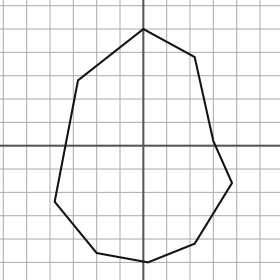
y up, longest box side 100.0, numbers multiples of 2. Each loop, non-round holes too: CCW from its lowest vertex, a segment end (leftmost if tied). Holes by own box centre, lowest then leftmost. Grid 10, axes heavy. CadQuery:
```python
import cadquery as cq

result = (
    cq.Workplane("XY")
    .moveTo(2.0, -50.0)
    .lineTo(22.0, -42.0)
    .lineTo(38.0, -16.0)
    .lineTo(30.0, 2.0)
    .lineTo(22.0, 38.0)
    .lineTo(0.0, 50.0)
    .lineTo(-28.0, 28.0)
    .lineTo(-38.0, -24.0)
    .lineTo(-20.0, -46.0)
    .close()
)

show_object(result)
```